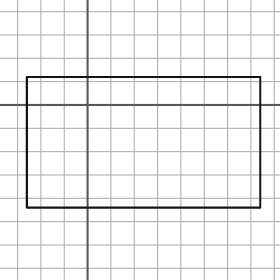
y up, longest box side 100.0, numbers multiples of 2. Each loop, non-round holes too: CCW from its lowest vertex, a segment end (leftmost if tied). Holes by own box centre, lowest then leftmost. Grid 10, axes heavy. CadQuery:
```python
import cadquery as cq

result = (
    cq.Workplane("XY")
    .moveTo(-26.0, -44.0)
    .lineTo(74.0, -44.0)
    .lineTo(74.0, 12.0)
    .lineTo(-26.0, 12.0)
    .close()
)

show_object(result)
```